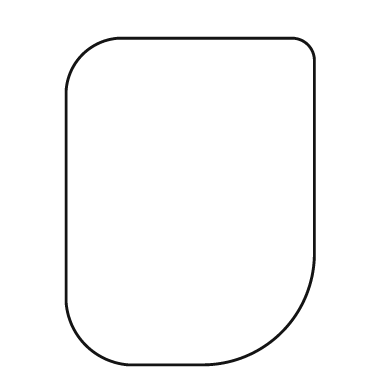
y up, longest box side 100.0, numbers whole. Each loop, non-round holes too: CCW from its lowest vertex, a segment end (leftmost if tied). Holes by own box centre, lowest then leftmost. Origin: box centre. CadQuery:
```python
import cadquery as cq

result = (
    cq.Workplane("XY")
    .moveTo(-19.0, -50.0)
    .lineTo(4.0, -50.0)
    .threePointArc((28.0, -40.0), (38.0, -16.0))
    .lineTo(38.0, 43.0)
    .threePointArc((36.0, 48.0), (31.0, 50.0))
    .lineTo(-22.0, 50.0)
    .threePointArc((-33.0, 45.0), (-38.0, 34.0))
    .lineTo(-38.0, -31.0)
    .threePointArc((-32.0, -44.0), (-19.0, -50.0))
    .close()
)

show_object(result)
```